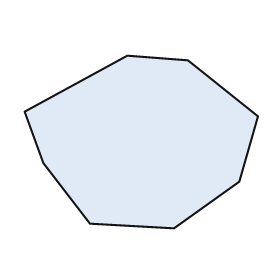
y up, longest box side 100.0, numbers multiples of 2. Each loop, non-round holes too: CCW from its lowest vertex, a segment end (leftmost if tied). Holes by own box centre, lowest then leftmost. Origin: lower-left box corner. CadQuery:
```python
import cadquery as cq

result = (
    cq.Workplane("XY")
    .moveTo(64.0, 0.0)
    .lineTo(92.0, 20.0)
    .lineTo(100.0, 48.0)
    .lineTo(70.0, 72.0)
    .lineTo(44.0, 74.0)
    .lineTo(0.0, 50.0)
    .lineTo(8.0, 28.0)
    .lineTo(28.0, 2.0)
    .close()
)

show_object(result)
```